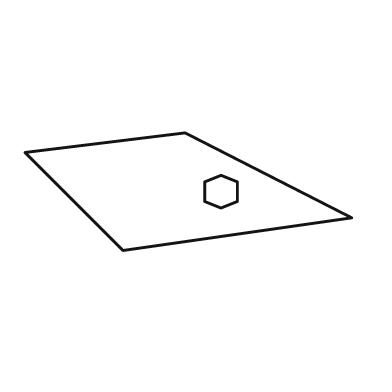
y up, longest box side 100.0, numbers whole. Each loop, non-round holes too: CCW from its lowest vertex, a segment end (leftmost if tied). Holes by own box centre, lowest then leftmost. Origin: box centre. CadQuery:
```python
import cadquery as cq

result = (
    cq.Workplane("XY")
    .moveTo(-20.0, -18.0)
    .lineTo(50.0, -8.0)
    .lineTo(-1.0, 18.0)
    .lineTo(-50.0, 12.0)
    .close()
    .moveTo(10.0, -5.0)
    .lineTo(15.0, -3.0)
    .lineTo(15.0, 3.0)
    .lineTo(10.0, 5.0)
    .lineTo(5.0, 3.0)
    .lineTo(5.0, -3.0)
    .close()
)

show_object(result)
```